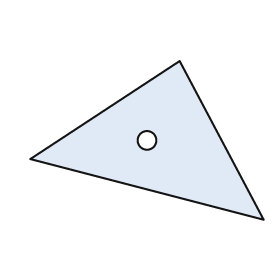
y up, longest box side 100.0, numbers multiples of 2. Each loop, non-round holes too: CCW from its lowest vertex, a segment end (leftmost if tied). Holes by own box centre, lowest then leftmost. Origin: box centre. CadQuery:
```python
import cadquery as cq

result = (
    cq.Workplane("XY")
    .moveTo(50.0, -34.0)
    .lineTo(14.0, 34.0)
    .lineTo(-50.0, -8.0)
    .close()
    .moveTo(0.0, 0.0)
    .circle(4.0)
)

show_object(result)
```